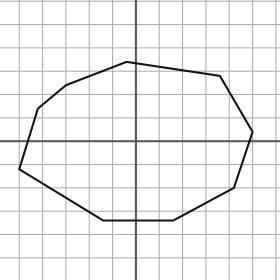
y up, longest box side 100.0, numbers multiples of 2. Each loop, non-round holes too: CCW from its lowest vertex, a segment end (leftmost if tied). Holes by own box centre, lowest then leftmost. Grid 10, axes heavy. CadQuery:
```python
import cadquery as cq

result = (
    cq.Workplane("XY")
    .moveTo(-14.0, -34.0)
    .lineTo(16.0, -34.0)
    .lineTo(42.0, -20.0)
    .lineTo(50.0, 4.0)
    .lineTo(36.0, 28.0)
    .lineTo(-4.0, 34.0)
    .lineTo(-30.0, 24.0)
    .lineTo(-42.0, 14.0)
    .lineTo(-50.0, -12.0)
    .close()
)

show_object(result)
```